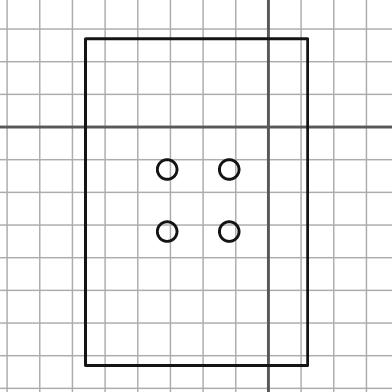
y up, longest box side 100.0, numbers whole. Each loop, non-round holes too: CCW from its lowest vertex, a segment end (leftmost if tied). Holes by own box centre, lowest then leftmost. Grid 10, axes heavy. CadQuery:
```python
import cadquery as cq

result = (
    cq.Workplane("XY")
    .moveTo(-56.0, -73.0)
    .lineTo(12.0, -73.0)
    .lineTo(12.0, 27.0)
    .lineTo(-56.0, 27.0)
    .close()
    .moveTo(-31.0, -32.0)
    .circle(3.0)
    .moveTo(-12.0, -32.0)
    .circle(3.0)
    .moveTo(-31.0, -13.0)
    .circle(3.0)
    .moveTo(-12.0, -13.0)
    .circle(3.0)
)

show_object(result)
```